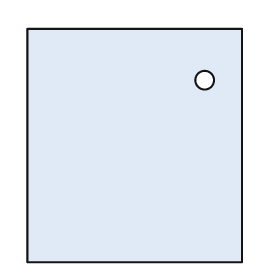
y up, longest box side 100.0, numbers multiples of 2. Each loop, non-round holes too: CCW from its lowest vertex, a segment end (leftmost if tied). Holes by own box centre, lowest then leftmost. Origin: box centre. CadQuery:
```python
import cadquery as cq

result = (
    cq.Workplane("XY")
    .moveTo(-46.0, -50.0)
    .lineTo(46.0, -50.0)
    .lineTo(46.0, 50.0)
    .lineTo(-46.0, 50.0)
    .close()
    .moveTo(30.0, 28.0)
    .circle(4.0)
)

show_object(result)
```